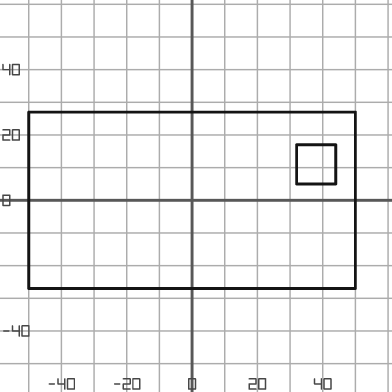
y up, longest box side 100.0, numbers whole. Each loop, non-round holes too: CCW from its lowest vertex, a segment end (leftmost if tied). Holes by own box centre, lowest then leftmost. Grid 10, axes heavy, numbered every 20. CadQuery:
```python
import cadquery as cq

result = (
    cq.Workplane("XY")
    .moveTo(-50.0, -27.0)
    .lineTo(50.0, -27.0)
    .lineTo(50.0, 27.0)
    .lineTo(-50.0, 27.0)
    .close()
    .moveTo(32.0, 5.0)
    .lineTo(44.0, 5.0)
    .lineTo(44.0, 17.0)
    .lineTo(32.0, 17.0)
    .close()
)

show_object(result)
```